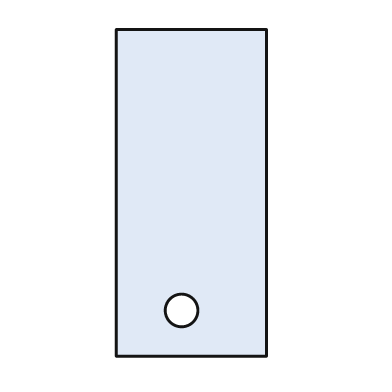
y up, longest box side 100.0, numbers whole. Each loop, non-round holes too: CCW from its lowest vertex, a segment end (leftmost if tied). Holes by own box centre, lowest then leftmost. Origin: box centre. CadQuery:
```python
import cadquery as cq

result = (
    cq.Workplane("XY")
    .moveTo(-23.0, -50.0)
    .lineTo(23.0, -50.0)
    .lineTo(23.0, 50.0)
    .lineTo(-23.0, 50.0)
    .close()
    .moveTo(-3.0, -36.0)
    .circle(5.0)
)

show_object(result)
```